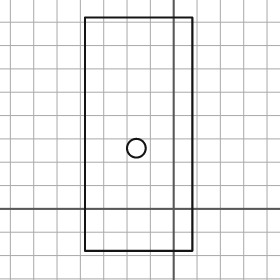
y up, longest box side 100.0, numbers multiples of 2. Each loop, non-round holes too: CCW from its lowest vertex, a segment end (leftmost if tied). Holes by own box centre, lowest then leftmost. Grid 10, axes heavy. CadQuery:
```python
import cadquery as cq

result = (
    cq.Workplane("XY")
    .moveTo(-38.0, -18.0)
    .lineTo(8.0, -18.0)
    .lineTo(8.0, 82.0)
    .lineTo(-38.0, 82.0)
    .close()
    .moveTo(-16.0, 26.0)
    .circle(4.0)
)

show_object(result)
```